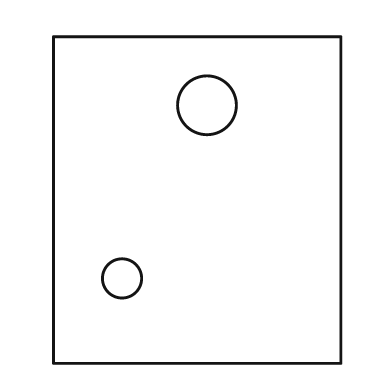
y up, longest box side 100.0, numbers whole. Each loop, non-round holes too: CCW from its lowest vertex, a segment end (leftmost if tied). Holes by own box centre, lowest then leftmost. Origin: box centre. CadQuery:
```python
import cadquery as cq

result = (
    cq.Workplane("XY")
    .moveTo(-44.0, -50.0)
    .lineTo(44.0, -50.0)
    .lineTo(44.0, 50.0)
    .lineTo(-44.0, 50.0)
    .close()
    .moveTo(-23.0, -24.0)
    .circle(6.0)
    .moveTo(3.0, 29.0)
    .circle(9.0)
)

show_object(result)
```